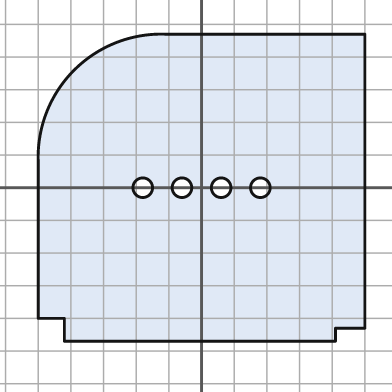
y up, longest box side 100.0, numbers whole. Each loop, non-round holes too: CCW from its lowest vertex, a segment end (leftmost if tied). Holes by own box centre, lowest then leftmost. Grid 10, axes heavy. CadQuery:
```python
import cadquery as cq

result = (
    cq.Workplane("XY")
    .moveTo(-42.0, -47.0)
    .lineTo(41.0, -47.0)
    .lineTo(41.0, -43.0)
    .lineTo(50.0, -43.0)
    .lineTo(50.0, 47.0)
    .lineTo(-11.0, 47.0)
    .threePointArc((-39.0, 36.0), (-50.0, 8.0))
    .lineTo(-50.0, -40.0)
    .lineTo(-42.0, -40.0)
    .close()
    .moveTo(-18.0, 0.0)
    .circle(3.0)
    .moveTo(-6.0, 0.0)
    .circle(3.0)
    .moveTo(6.0, 0.0)
    .circle(3.0)
    .moveTo(18.0, 0.0)
    .circle(3.0)
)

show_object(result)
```